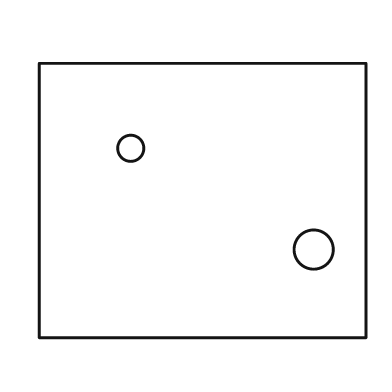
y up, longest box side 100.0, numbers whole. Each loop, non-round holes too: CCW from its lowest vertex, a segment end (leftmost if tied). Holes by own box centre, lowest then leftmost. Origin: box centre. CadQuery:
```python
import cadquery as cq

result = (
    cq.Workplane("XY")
    .moveTo(-50.0, -42.0)
    .lineTo(50.0, -42.0)
    .lineTo(50.0, 42.0)
    .lineTo(-50.0, 42.0)
    .close()
    .moveTo(34.0, -15.0)
    .circle(6.0)
    .moveTo(-22.0, 16.0)
    .circle(4.0)
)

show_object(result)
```